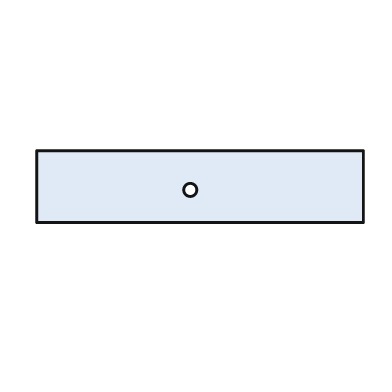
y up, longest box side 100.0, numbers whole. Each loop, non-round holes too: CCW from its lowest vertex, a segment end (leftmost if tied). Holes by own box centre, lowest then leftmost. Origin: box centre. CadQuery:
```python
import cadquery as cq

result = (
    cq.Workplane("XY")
    .moveTo(-50.0, -11.0)
    .lineTo(50.0, -11.0)
    .lineTo(50.0, 11.0)
    .lineTo(-50.0, 11.0)
    .close()
    .moveTo(-3.0, -1.0)
    .circle(2.0)
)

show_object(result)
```